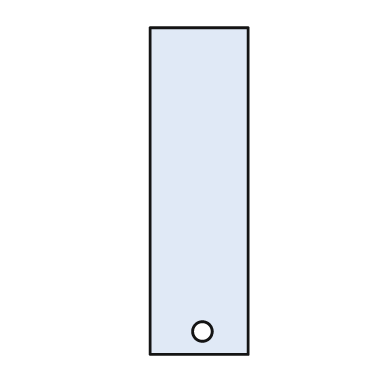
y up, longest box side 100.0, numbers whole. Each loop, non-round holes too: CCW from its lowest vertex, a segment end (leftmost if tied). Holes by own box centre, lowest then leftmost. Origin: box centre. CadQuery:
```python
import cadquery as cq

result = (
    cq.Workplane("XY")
    .moveTo(-15.0, -50.0)
    .lineTo(15.0, -50.0)
    .lineTo(15.0, 50.0)
    .lineTo(-15.0, 50.0)
    .close()
    .moveTo(1.0, -43.0)
    .circle(3.0)
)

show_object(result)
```